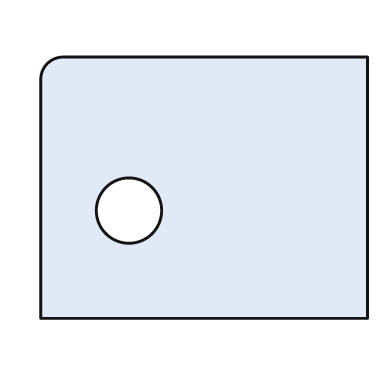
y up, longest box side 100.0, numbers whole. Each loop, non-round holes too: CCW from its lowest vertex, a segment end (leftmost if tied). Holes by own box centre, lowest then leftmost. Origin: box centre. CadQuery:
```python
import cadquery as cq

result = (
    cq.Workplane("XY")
    .moveTo(-50.0, -40.0)
    .lineTo(50.0, -40.0)
    .lineTo(50.0, 40.0)
    .lineTo(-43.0, 40.0)
    .threePointArc((-48.0, 38.0), (-50.0, 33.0))
    .close()
    .moveTo(-23.0, -7.0)
    .circle(10.0)
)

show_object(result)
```